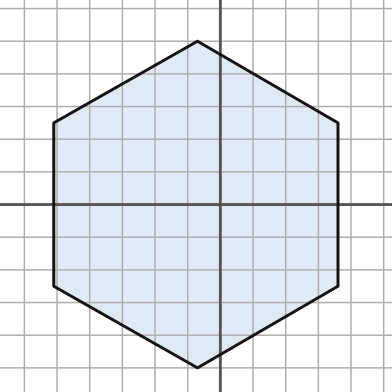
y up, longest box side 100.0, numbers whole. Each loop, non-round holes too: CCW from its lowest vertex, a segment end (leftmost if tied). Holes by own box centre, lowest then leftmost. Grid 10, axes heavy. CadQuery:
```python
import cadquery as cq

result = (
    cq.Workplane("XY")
    .moveTo(-7.0, -50.0)
    .lineTo(36.0, -25.0)
    .lineTo(36.0, 25.0)
    .lineTo(-7.0, 50.0)
    .lineTo(-51.0, 25.0)
    .lineTo(-51.0, -25.0)
    .close()
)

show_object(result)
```